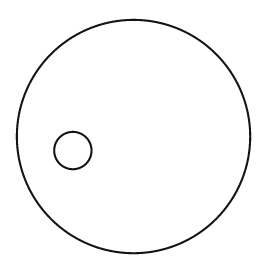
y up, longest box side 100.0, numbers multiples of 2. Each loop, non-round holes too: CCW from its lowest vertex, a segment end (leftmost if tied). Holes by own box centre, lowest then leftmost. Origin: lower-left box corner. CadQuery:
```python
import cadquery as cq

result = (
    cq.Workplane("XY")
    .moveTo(50.0, 50.0)
    .circle(50.0)
    .moveTo(24.0, 44.0)
    .circle(8.0)
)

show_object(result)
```